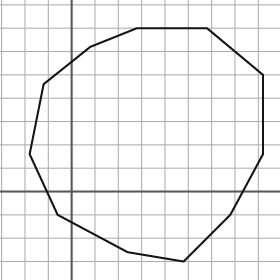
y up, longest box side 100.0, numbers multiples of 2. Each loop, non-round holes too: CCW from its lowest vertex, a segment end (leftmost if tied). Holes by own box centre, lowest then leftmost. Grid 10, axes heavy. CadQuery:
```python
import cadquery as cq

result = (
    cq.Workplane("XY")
    .moveTo(48.0, -30.0)
    .lineTo(68.0, -10.0)
    .lineTo(82.0, 16.0)
    .lineTo(82.0, 50.0)
    .lineTo(58.0, 70.0)
    .lineTo(28.0, 70.0)
    .lineTo(8.0, 62.0)
    .lineTo(-12.0, 46.0)
    .lineTo(-18.0, 16.0)
    .lineTo(-6.0, -10.0)
    .lineTo(24.0, -26.0)
    .close()
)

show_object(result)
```